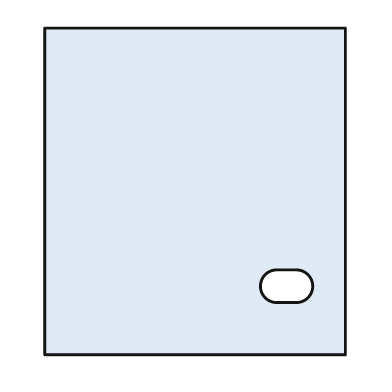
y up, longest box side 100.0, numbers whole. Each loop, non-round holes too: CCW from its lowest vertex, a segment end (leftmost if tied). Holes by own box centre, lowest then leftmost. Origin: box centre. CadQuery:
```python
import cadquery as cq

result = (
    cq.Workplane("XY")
    .moveTo(-46.0, -50.0)
    .lineTo(46.0, -50.0)
    .lineTo(46.0, 50.0)
    .lineTo(-46.0, 50.0)
    .close()
    .moveTo(25.0, -34.0)
    .lineTo(31.0, -34.0)
    .threePointArc((36.0, -29.0), (31.0, -24.0))
    .lineTo(25.0, -24.0)
    .threePointArc((20.0, -29.0), (25.0, -34.0))
    .close()
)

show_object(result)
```